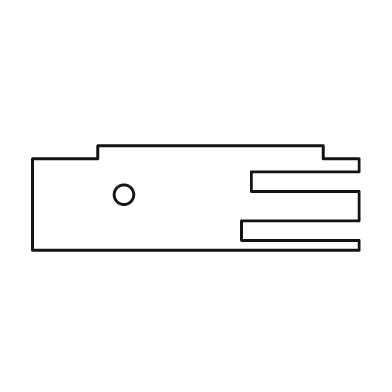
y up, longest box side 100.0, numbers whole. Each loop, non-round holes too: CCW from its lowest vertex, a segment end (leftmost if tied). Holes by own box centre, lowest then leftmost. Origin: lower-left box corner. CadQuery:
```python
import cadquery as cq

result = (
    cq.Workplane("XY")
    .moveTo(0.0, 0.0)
    .lineTo(100.0, 0.0)
    .lineTo(100.0, 3.0)
    .lineTo(64.0, 3.0)
    .lineTo(64.0, 9.0)
    .lineTo(100.0, 9.0)
    .lineTo(100.0, 18.0)
    .lineTo(67.0, 18.0)
    .lineTo(67.0, 24.0)
    .lineTo(100.0, 24.0)
    .lineTo(100.0, 28.0)
    .lineTo(89.0, 28.0)
    .lineTo(89.0, 32.0)
    .lineTo(20.0, 32.0)
    .lineTo(20.0, 28.0)
    .lineTo(0.0, 28.0)
    .close()
    .moveTo(28.0, 17.0)
    .circle(3.0)
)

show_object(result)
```